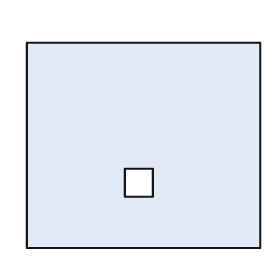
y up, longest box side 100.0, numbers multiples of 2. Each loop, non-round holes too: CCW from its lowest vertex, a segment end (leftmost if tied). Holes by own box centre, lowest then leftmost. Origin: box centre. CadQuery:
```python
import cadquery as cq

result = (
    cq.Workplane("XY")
    .moveTo(-50.0, -44.0)
    .lineTo(50.0, -44.0)
    .lineTo(50.0, 44.0)
    .lineTo(-50.0, 44.0)
    .close()
    .moveTo(-8.0, -22.0)
    .lineTo(4.0, -22.0)
    .lineTo(4.0, -10.0)
    .lineTo(-8.0, -10.0)
    .close()
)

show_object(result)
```